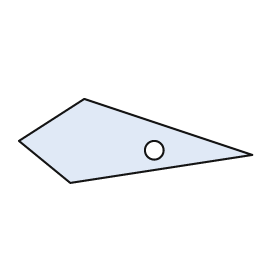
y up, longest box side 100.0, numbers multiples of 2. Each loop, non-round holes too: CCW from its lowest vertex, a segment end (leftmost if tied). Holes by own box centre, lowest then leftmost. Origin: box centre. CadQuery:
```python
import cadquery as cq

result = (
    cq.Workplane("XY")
    .moveTo(-28.0, -18.0)
    .lineTo(50.0, -6.0)
    .lineTo(-22.0, 18.0)
    .lineTo(-50.0, 0.0)
    .close()
    .moveTo(8.0, -4.0)
    .circle(4.0)
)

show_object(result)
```